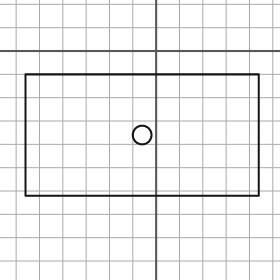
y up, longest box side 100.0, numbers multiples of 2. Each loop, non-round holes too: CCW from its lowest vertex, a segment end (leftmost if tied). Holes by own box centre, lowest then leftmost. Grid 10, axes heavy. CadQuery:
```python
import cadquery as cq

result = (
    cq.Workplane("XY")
    .moveTo(-56.0, -62.0)
    .lineTo(44.0, -62.0)
    .lineTo(44.0, -10.0)
    .lineTo(-56.0, -10.0)
    .close()
    .moveTo(-6.0, -36.0)
    .circle(4.0)
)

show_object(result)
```